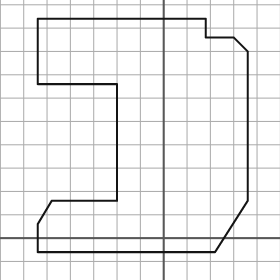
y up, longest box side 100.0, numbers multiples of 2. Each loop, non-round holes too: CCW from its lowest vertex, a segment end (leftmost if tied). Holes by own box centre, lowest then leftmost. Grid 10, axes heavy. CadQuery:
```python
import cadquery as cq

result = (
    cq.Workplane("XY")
    .moveTo(-54.0, -6.0)
    .lineTo(22.0, -6.0)
    .lineTo(36.0, 16.0)
    .lineTo(36.0, 80.0)
    .lineTo(30.0, 86.0)
    .lineTo(18.0, 86.0)
    .lineTo(18.0, 94.0)
    .lineTo(-54.0, 94.0)
    .lineTo(-54.0, 66.0)
    .lineTo(-20.0, 66.0)
    .lineTo(-20.0, 16.0)
    .lineTo(-48.0, 16.0)
    .lineTo(-54.0, 6.0)
    .close()
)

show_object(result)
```